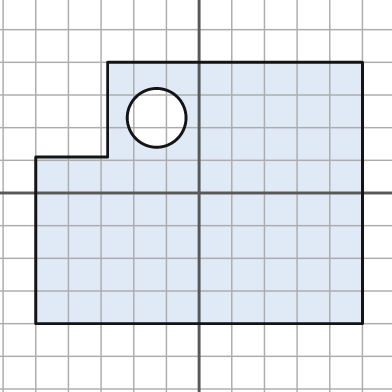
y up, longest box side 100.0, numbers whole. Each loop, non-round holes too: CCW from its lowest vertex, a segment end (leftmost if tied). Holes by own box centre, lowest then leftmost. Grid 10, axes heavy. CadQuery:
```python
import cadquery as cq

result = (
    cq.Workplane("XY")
    .moveTo(-50.0, -40.0)
    .lineTo(50.0, -40.0)
    .lineTo(50.0, 40.0)
    .lineTo(-28.0, 40.0)
    .lineTo(-28.0, 11.0)
    .lineTo(-50.0, 11.0)
    .close()
    .moveTo(-13.0, 23.0)
    .circle(9.0)
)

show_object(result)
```